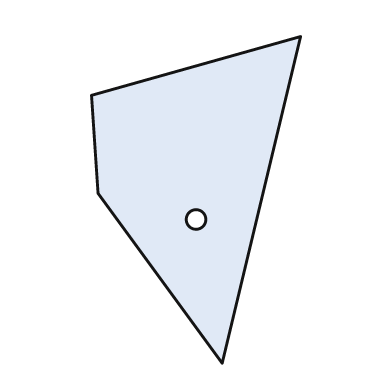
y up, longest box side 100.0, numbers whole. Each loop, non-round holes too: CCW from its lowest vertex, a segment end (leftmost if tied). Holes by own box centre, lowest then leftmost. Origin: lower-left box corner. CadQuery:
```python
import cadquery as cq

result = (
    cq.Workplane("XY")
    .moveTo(40.0, 0.0)
    .lineTo(64.0, 100.0)
    .lineTo(0.0, 82.0)
    .lineTo(2.0, 52.0)
    .close()
    .moveTo(32.0, 44.0)
    .circle(3.0)
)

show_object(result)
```